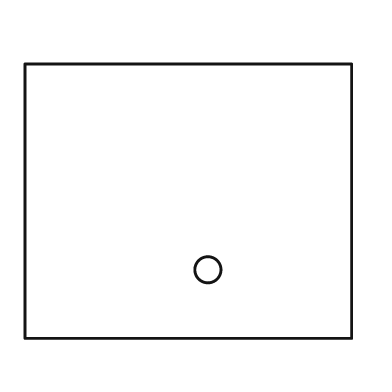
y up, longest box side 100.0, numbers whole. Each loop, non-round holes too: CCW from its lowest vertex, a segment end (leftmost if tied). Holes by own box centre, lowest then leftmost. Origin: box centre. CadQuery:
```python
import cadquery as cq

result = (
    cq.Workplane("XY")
    .moveTo(-50.0, -42.0)
    .lineTo(50.0, -42.0)
    .lineTo(50.0, 42.0)
    .lineTo(-50.0, 42.0)
    .close()
    .moveTo(6.0, -21.0)
    .circle(4.0)
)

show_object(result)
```